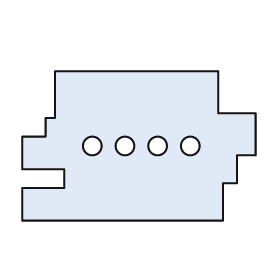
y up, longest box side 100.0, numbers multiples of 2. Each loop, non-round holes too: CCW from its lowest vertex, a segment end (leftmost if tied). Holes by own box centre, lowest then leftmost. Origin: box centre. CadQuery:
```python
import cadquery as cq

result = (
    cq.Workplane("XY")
    .moveTo(-50.0, -32.0)
    .lineTo(36.0, -32.0)
    .lineTo(36.0, -16.0)
    .lineTo(42.0, -16.0)
    .lineTo(42.0, -4.0)
    .lineTo(50.0, -4.0)
    .lineTo(50.0, 14.0)
    .lineTo(34.0, 14.0)
    .lineTo(34.0, 32.0)
    .lineTo(-36.0, 32.0)
    .lineTo(-36.0, 12.0)
    .lineTo(-40.0, 12.0)
    .lineTo(-40.0, 4.0)
    .lineTo(-50.0, 4.0)
    .lineTo(-50.0, -10.0)
    .lineTo(-32.0, -10.0)
    .lineTo(-32.0, -18.0)
    .lineTo(-50.0, -18.0)
    .close()
    .moveTo(-20.0, 0.0)
    .circle(4.0)
    .moveTo(-6.0, 0.0)
    .circle(4.0)
    .moveTo(8.0, 0.0)
    .circle(4.0)
    .moveTo(22.0, 0.0)
    .circle(4.0)
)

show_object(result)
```